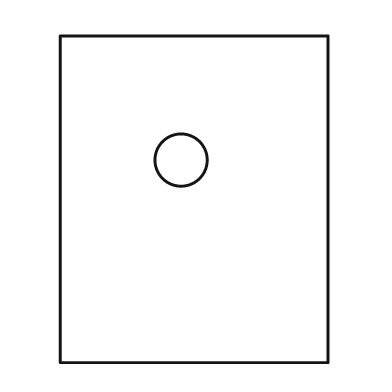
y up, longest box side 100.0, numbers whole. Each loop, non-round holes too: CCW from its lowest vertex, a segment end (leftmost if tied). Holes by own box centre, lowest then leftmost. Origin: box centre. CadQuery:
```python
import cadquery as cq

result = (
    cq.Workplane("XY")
    .moveTo(-41.0, -50.0)
    .lineTo(41.0, -50.0)
    .lineTo(41.0, 50.0)
    .lineTo(-41.0, 50.0)
    .close()
    .moveTo(-4.0, 12.0)
    .circle(8.0)
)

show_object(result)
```